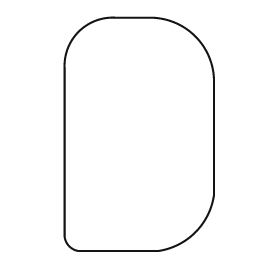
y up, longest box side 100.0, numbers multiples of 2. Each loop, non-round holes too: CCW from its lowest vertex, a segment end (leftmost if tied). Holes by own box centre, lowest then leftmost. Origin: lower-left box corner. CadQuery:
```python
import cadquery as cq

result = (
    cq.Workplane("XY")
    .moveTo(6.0, 0.0)
    .lineTo(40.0, 0.0)
    .threePointArc((56.0, 8.0), (64.0, 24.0))
    .lineTo(64.0, 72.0)
    .threePointArc((56.0, 92.0), (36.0, 100.0))
    .lineTo(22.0, 100.0)
    .threePointArc((6.0, 94.0), (0.0, 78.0))
    .lineTo(0.0, 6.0)
    .threePointArc((2.0, 2.0), (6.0, 0.0))
    .close()
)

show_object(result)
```